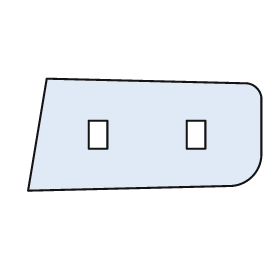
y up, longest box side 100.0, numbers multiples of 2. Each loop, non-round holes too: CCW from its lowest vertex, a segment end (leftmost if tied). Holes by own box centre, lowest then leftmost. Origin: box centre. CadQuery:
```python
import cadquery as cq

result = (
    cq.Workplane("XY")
    .moveTo(-50.0, -24.0)
    .lineTo(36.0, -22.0)
    .threePointArc((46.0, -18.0), (50.0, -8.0))
    .lineTo(50.0, 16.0)
    .threePointArc((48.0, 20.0), (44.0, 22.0))
    .lineTo(-42.0, 24.0)
    .close()
    .moveTo(-24.0, -6.0)
    .lineTo(-16.0, -6.0)
    .lineTo(-16.0, 6.0)
    .lineTo(-24.0, 6.0)
    .close()
    .moveTo(18.0, -6.0)
    .lineTo(26.0, -6.0)
    .lineTo(26.0, 6.0)
    .lineTo(18.0, 6.0)
    .close()
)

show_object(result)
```